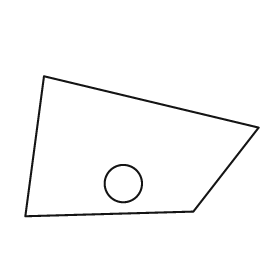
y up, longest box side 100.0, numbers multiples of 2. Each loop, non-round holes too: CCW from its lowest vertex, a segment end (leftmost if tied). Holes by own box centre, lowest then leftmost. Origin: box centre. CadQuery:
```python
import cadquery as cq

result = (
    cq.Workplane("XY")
    .moveTo(-50.0, -30.0)
    .lineTo(22.0, -28.0)
    .lineTo(50.0, 8.0)
    .lineTo(-42.0, 30.0)
    .close()
    .moveTo(-8.0, -16.0)
    .circle(8.0)
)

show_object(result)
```